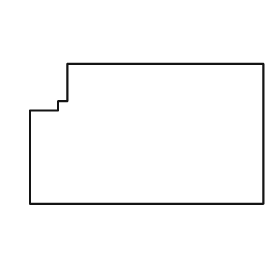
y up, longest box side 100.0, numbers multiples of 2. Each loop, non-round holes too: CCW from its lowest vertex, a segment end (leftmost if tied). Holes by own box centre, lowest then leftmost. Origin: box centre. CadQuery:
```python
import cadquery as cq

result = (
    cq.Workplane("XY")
    .moveTo(-50.0, -30.0)
    .lineTo(50.0, -30.0)
    .lineTo(50.0, 30.0)
    .lineTo(-34.0, 30.0)
    .lineTo(-34.0, 14.0)
    .lineTo(-38.0, 14.0)
    .lineTo(-38.0, 10.0)
    .lineTo(-50.0, 10.0)
    .close()
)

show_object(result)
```